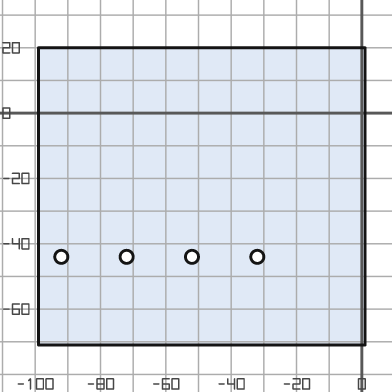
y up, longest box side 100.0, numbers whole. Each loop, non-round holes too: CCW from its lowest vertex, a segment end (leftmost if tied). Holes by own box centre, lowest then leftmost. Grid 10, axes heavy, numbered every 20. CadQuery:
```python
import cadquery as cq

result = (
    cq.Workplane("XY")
    .moveTo(-99.0, -71.0)
    .lineTo(1.0, -71.0)
    .lineTo(1.0, 20.0)
    .lineTo(-99.0, 20.0)
    .close()
    .moveTo(-92.0, -44.0)
    .circle(2.0)
    .moveTo(-72.0, -44.0)
    .circle(2.0)
    .moveTo(-52.0, -44.0)
    .circle(2.0)
    .moveTo(-32.0, -44.0)
    .circle(2.0)
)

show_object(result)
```